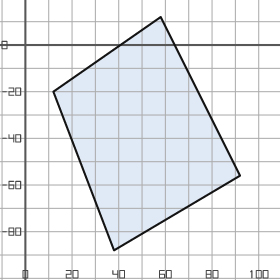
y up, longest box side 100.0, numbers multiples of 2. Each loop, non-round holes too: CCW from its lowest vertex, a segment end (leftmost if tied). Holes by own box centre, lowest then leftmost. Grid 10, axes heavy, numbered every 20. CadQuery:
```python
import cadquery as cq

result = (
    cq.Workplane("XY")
    .moveTo(38.0, -88.0)
    .lineTo(92.0, -56.0)
    .lineTo(58.0, 12.0)
    .lineTo(12.0, -20.0)
    .close()
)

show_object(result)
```